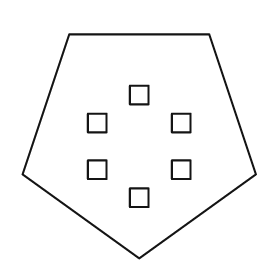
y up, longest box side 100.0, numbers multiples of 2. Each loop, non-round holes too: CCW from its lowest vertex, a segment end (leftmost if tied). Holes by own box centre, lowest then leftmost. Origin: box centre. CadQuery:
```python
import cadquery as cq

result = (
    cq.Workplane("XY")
    .moveTo(0.0, -48.0)
    .lineTo(50.0, -12.0)
    .lineTo(30.0, 48.0)
    .lineTo(-30.0, 48.0)
    .lineTo(-50.0, -12.0)
    .close()
    .moveTo(-4.0, -26.0)
    .lineTo(4.0, -26.0)
    .lineTo(4.0, -18.0)
    .lineTo(-4.0, -18.0)
    .close()
    .moveTo(-22.0, -14.0)
    .lineTo(-14.0, -14.0)
    .lineTo(-14.0, -6.0)
    .lineTo(-22.0, -6.0)
    .close()
    .moveTo(14.0, -14.0)
    .lineTo(22.0, -14.0)
    .lineTo(22.0, -6.0)
    .lineTo(14.0, -6.0)
    .close()
    .moveTo(-22.0, 6.0)
    .lineTo(-14.0, 6.0)
    .lineTo(-14.0, 14.0)
    .lineTo(-22.0, 14.0)
    .close()
    .moveTo(14.0, 6.0)
    .lineTo(22.0, 6.0)
    .lineTo(22.0, 14.0)
    .lineTo(14.0, 14.0)
    .close()
    .moveTo(-4.0, 18.0)
    .lineTo(4.0, 18.0)
    .lineTo(4.0, 26.0)
    .lineTo(-4.0, 26.0)
    .close()
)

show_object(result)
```